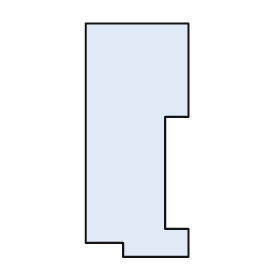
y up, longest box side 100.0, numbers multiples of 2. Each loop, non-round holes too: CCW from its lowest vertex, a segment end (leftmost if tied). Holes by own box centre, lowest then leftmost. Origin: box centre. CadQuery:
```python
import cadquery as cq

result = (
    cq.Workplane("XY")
    .moveTo(-6.0, -50.0)
    .lineTo(22.0, -50.0)
    .lineTo(22.0, -38.0)
    .lineTo(12.0, -38.0)
    .lineTo(12.0, 10.0)
    .lineTo(22.0, 10.0)
    .lineTo(22.0, 50.0)
    .lineTo(-22.0, 50.0)
    .lineTo(-22.0, -44.0)
    .lineTo(-6.0, -44.0)
    .close()
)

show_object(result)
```